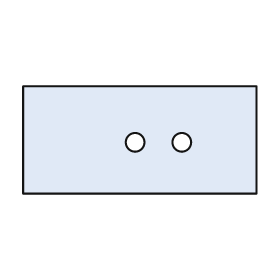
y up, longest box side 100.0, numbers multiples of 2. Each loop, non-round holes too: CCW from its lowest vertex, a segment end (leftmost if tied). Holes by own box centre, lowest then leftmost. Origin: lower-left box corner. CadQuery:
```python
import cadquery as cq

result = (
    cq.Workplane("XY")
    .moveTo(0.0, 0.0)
    .lineTo(100.0, 0.0)
    .lineTo(100.0, 46.0)
    .lineTo(0.0, 46.0)
    .close()
    .moveTo(48.0, 22.0)
    .circle(4.0)
    .moveTo(68.0, 22.0)
    .circle(4.0)
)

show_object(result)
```